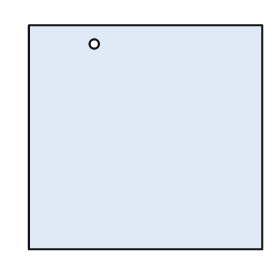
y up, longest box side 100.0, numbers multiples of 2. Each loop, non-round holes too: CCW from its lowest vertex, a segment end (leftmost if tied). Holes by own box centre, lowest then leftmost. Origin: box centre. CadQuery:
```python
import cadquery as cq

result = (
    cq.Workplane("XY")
    .moveTo(-50.0, -48.0)
    .lineTo(50.0, -48.0)
    .lineTo(50.0, 48.0)
    .lineTo(-50.0, 48.0)
    .close()
    .moveTo(-22.0, 40.0)
    .circle(2.0)
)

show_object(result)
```